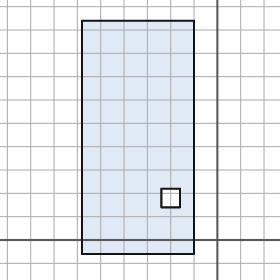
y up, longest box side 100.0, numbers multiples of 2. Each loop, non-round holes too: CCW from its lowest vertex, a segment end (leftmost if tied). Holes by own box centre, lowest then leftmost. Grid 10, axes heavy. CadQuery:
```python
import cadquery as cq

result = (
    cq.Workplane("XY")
    .moveTo(-58.0, -6.0)
    .lineTo(-10.0, -6.0)
    .lineTo(-10.0, 94.0)
    .lineTo(-58.0, 94.0)
    .close()
    .moveTo(-24.0, 14.0)
    .lineTo(-16.0, 14.0)
    .lineTo(-16.0, 22.0)
    .lineTo(-24.0, 22.0)
    .close()
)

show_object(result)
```